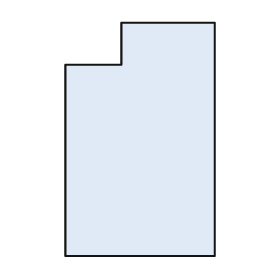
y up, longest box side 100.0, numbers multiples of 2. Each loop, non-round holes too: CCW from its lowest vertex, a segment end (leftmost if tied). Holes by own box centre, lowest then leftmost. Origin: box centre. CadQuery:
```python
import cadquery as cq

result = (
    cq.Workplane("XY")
    .moveTo(-32.0, -50.0)
    .lineTo(32.0, -50.0)
    .lineTo(32.0, 50.0)
    .lineTo(-8.0, 50.0)
    .lineTo(-8.0, 32.0)
    .lineTo(-32.0, 32.0)
    .close()
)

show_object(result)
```